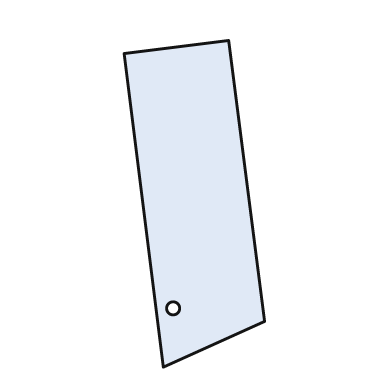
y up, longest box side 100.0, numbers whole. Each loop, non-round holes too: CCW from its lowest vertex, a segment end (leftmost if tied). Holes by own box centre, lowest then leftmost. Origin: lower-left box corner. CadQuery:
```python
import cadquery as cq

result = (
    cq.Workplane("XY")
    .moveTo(12.0, 0.0)
    .lineTo(43.0, 14.0)
    .lineTo(32.0, 100.0)
    .lineTo(0.0, 96.0)
    .close()
    .moveTo(15.0, 18.0)
    .circle(2.0)
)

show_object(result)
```